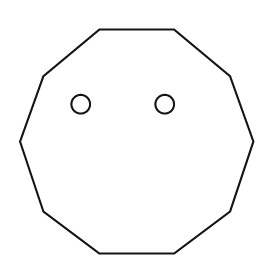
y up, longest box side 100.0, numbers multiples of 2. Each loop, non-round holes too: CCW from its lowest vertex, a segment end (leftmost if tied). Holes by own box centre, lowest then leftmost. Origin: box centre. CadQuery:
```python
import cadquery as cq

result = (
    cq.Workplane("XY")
    .moveTo(-16.0, -48.0)
    .lineTo(16.0, -48.0)
    .lineTo(40.0, -30.0)
    .lineTo(50.0, 0.0)
    .lineTo(40.0, 28.0)
    .lineTo(16.0, 48.0)
    .lineTo(-16.0, 48.0)
    .lineTo(-40.0, 28.0)
    .lineTo(-50.0, 0.0)
    .lineTo(-40.0, -30.0)
    .close()
    .moveTo(-24.0, 16.0)
    .circle(4.0)
    .moveTo(12.0, 16.0)
    .circle(4.0)
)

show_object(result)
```